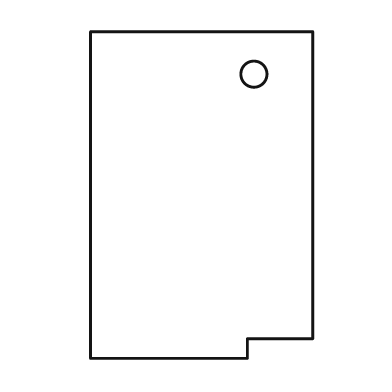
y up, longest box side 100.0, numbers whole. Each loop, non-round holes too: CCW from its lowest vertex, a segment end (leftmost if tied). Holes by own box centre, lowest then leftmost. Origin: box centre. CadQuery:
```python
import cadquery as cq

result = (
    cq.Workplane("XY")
    .moveTo(-34.0, -50.0)
    .lineTo(14.0, -50.0)
    .lineTo(14.0, -44.0)
    .lineTo(34.0, -44.0)
    .lineTo(34.0, 50.0)
    .lineTo(-34.0, 50.0)
    .close()
    .moveTo(16.0, 37.0)
    .circle(4.0)
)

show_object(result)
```